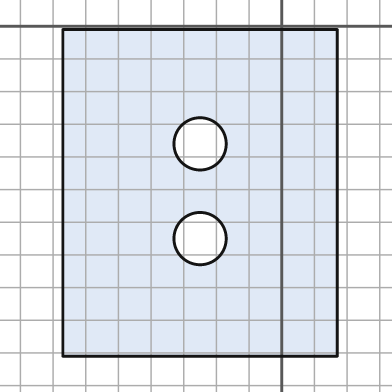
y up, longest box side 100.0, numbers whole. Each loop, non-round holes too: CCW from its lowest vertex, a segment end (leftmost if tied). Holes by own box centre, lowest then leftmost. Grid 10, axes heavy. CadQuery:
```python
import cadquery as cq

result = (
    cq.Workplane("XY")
    .moveTo(-67.0, -101.0)
    .lineTo(17.0, -101.0)
    .lineTo(17.0, -1.0)
    .lineTo(-67.0, -1.0)
    .close()
    .moveTo(-25.0, -65.0)
    .circle(8.0)
    .moveTo(-25.0, -36.0)
    .circle(8.0)
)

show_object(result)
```